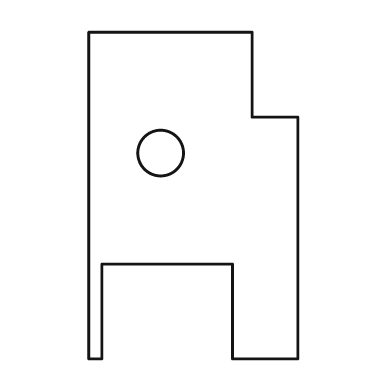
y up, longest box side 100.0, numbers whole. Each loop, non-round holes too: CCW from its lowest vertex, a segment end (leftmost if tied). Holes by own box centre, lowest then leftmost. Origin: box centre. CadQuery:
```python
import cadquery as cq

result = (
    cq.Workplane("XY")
    .moveTo(-32.0, -50.0)
    .lineTo(-28.0, -50.0)
    .lineTo(-28.0, -21.0)
    .lineTo(12.0, -21.0)
    .lineTo(12.0, -50.0)
    .lineTo(32.0, -50.0)
    .lineTo(32.0, 24.0)
    .lineTo(18.0, 24.0)
    .lineTo(18.0, 50.0)
    .lineTo(-32.0, 50.0)
    .close()
    .moveTo(-10.0, 13.0)
    .circle(7.0)
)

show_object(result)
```